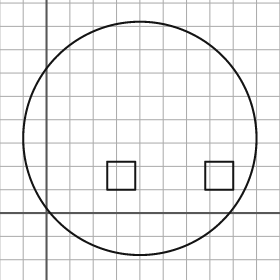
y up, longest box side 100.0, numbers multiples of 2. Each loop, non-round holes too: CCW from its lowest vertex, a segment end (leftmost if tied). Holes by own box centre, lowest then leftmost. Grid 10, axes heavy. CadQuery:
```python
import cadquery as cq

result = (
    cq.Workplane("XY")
    .moveTo(40.0, 32.0)
    .circle(50.0)
    .moveTo(26.0, 10.0)
    .lineTo(38.0, 10.0)
    .lineTo(38.0, 22.0)
    .lineTo(26.0, 22.0)
    .close()
    .moveTo(68.0, 10.0)
    .lineTo(80.0, 10.0)
    .lineTo(80.0, 22.0)
    .lineTo(68.0, 22.0)
    .close()
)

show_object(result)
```